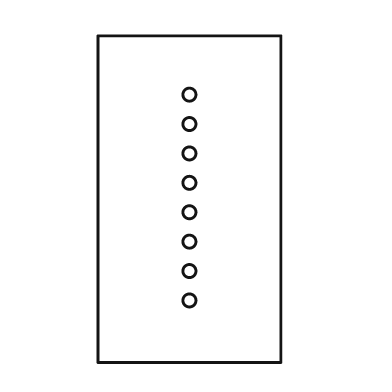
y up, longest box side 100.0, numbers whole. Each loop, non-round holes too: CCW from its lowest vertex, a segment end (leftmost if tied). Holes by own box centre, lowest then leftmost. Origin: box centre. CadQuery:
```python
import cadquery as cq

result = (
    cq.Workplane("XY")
    .moveTo(-28.0, -50.0)
    .lineTo(28.0, -50.0)
    .lineTo(28.0, 50.0)
    .lineTo(-28.0, 50.0)
    .close()
    .moveTo(0.0, -31.0)
    .circle(2.0)
    .moveTo(0.0, -22.0)
    .circle(2.0)
    .moveTo(0.0, -13.0)
    .circle(2.0)
    .moveTo(0.0, -4.0)
    .circle(2.0)
    .moveTo(0.0, 5.0)
    .circle(2.0)
    .moveTo(0.0, 14.0)
    .circle(2.0)
    .moveTo(0.0, 23.0)
    .circle(2.0)
    .moveTo(0.0, 32.0)
    .circle(2.0)
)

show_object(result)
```